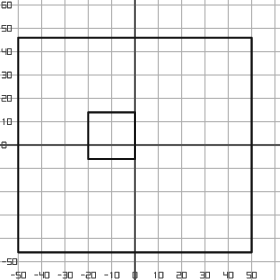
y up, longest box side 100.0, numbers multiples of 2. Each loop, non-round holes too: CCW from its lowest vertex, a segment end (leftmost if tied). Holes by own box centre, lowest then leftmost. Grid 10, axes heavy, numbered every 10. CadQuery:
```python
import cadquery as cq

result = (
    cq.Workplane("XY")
    .moveTo(-50.0, -46.0)
    .lineTo(50.0, -46.0)
    .lineTo(50.0, 46.0)
    .lineTo(-50.0, 46.0)
    .close()
    .moveTo(-20.0, -6.0)
    .lineTo(0.0, -6.0)
    .lineTo(0.0, 14.0)
    .lineTo(-20.0, 14.0)
    .close()
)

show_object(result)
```